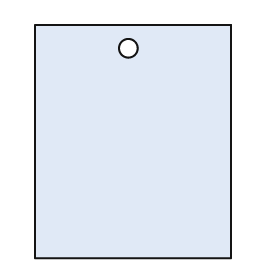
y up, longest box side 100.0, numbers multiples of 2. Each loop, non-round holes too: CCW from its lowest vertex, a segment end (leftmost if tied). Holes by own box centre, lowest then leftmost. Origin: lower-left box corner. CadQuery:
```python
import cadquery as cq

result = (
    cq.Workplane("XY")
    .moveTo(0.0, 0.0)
    .lineTo(84.0, 0.0)
    .lineTo(84.0, 100.0)
    .lineTo(0.0, 100.0)
    .close()
    .moveTo(40.0, 90.0)
    .circle(4.0)
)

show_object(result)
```